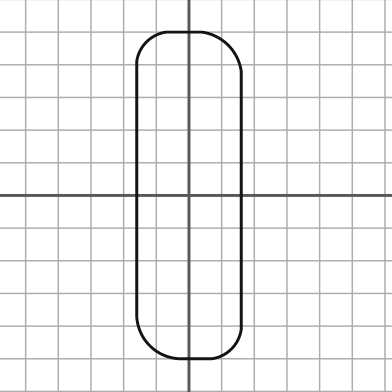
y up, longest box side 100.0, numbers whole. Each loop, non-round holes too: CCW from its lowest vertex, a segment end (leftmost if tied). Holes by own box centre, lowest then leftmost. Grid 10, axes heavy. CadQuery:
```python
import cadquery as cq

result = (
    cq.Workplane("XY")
    .moveTo(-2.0, -50.0)
    .lineTo(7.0, -50.0)
    .threePointArc((13.0, -47.0), (16.0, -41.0))
    .lineTo(16.0, 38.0)
    .threePointArc((12.0, 46.0), (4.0, 50.0))
    .lineTo(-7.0, 50.0)
    .threePointArc((-13.0, 47.0), (-16.0, 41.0))
    .lineTo(-16.0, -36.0)
    .threePointArc((-12.0, -46.0), (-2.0, -50.0))
    .close()
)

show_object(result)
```